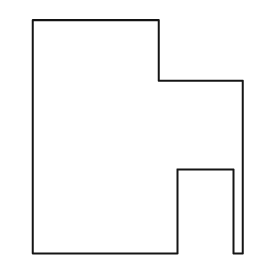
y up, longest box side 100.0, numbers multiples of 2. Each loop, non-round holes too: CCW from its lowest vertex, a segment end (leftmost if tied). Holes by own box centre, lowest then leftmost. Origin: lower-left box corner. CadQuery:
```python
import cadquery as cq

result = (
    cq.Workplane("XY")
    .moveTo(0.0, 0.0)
    .lineTo(62.0, 0.0)
    .lineTo(62.0, 36.0)
    .lineTo(86.0, 36.0)
    .lineTo(86.0, 0.0)
    .lineTo(90.0, 0.0)
    .lineTo(90.0, 74.0)
    .lineTo(54.0, 74.0)
    .lineTo(54.0, 100.0)
    .lineTo(0.0, 100.0)
    .close()
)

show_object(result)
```